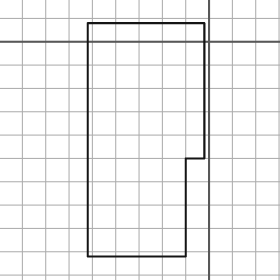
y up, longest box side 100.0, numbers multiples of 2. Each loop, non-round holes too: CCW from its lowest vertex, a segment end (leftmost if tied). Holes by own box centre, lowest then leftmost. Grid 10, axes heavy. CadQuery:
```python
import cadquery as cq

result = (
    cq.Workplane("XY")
    .moveTo(-52.0, -92.0)
    .lineTo(-10.0, -92.0)
    .lineTo(-10.0, -50.0)
    .lineTo(-2.0, -50.0)
    .lineTo(-2.0, 8.0)
    .lineTo(-52.0, 8.0)
    .close()
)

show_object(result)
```